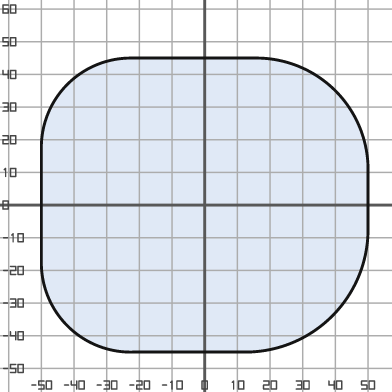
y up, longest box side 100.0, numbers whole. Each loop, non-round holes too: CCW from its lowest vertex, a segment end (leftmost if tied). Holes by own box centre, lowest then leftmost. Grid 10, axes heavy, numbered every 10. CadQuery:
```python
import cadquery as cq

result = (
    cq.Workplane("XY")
    .moveTo(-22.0, -45.0)
    .lineTo(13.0, -45.0)
    .threePointArc((39.0, -34.0), (50.0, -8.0))
    .lineTo(50.0, 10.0)
    .threePointArc((40.0, 35.0), (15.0, 45.0))
    .lineTo(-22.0, 45.0)
    .threePointArc((-42.0, 37.0), (-50.0, 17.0))
    .lineTo(-50.0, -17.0)
    .threePointArc((-42.0, -37.0), (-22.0, -45.0))
    .close()
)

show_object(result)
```